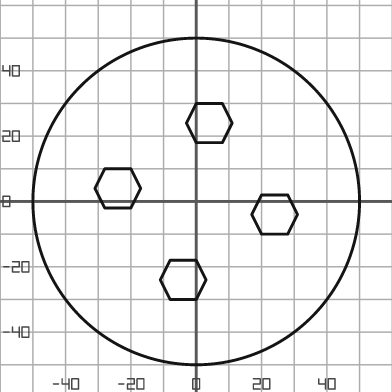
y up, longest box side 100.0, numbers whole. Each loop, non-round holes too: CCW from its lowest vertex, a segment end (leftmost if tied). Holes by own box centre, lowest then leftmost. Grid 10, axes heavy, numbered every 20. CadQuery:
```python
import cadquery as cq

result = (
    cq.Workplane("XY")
    .moveTo(0.0, 0.0)
    .circle(50.0)
    .moveTo(-8.0, -30.0)
    .lineTo(0.0, -30.0)
    .lineTo(3.0, -24.0)
    .lineTo(0.0, -18.0)
    .lineTo(-8.0, -18.0)
    .lineTo(-11.0, -24.0)
    .close()
    .moveTo(20.0, -10.0)
    .lineTo(28.0, -10.0)
    .lineTo(31.0, -4.0)
    .lineTo(28.0, 2.0)
    .lineTo(20.0, 2.0)
    .lineTo(17.0, -4.0)
    .close()
    .moveTo(-28.0, -2.0)
    .lineTo(-20.0, -2.0)
    .lineTo(-17.0, 4.0)
    .lineTo(-20.0, 10.0)
    .lineTo(-28.0, 10.0)
    .lineTo(-31.0, 4.0)
    .close()
    .moveTo(0.0, 18.0)
    .lineTo(8.0, 18.0)
    .lineTo(11.0, 24.0)
    .lineTo(8.0, 30.0)
    .lineTo(0.0, 30.0)
    .lineTo(-3.0, 24.0)
    .close()
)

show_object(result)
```